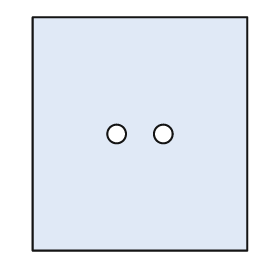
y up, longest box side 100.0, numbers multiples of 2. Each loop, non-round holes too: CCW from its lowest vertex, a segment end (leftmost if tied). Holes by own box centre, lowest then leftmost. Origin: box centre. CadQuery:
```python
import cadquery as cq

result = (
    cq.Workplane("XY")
    .moveTo(-46.0, -50.0)
    .lineTo(46.0, -50.0)
    .lineTo(46.0, 50.0)
    .lineTo(-46.0, 50.0)
    .close()
    .moveTo(-10.0, 0.0)
    .circle(4.0)
    .moveTo(10.0, 0.0)
    .circle(4.0)
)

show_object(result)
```